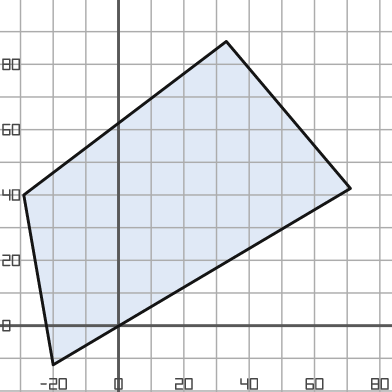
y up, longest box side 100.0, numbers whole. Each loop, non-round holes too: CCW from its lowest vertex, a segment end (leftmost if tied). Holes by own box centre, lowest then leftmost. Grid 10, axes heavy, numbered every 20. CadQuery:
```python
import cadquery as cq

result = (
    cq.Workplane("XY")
    .moveTo(-20.0, -12.0)
    .lineTo(71.0, 42.0)
    .lineTo(33.0, 87.0)
    .lineTo(-29.0, 40.0)
    .close()
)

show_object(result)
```